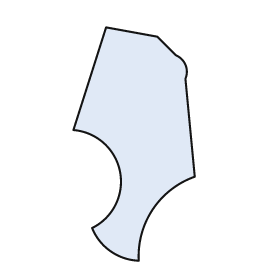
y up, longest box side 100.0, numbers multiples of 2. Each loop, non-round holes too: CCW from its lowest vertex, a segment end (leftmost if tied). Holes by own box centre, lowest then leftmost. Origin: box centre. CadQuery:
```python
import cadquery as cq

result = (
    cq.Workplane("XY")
    .moveTo(2.0, -50.0)
    .threePointArc((8.0, -28.0), (26.0, -14.0))
    .lineTo(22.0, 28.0)
    .threePointArc((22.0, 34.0), (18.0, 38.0))
    .lineTo(10.0, 46.0)
    .lineTo(-12.0, 50.0)
    .lineTo(-26.0, 6.0)
    .threePointArc((-6.0, -12.0), (-18.0, -36.0))
    .threePointArc((-10.0, -46.0), (2.0, -50.0))
    .close()
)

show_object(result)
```